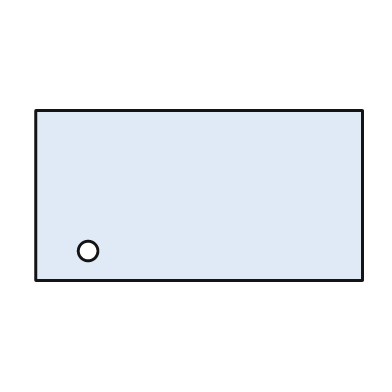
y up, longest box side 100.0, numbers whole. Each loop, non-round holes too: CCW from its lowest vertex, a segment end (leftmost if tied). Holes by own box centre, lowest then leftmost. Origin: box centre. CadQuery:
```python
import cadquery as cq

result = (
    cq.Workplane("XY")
    .moveTo(-50.0, -26.0)
    .lineTo(50.0, -26.0)
    .lineTo(50.0, 26.0)
    .lineTo(-50.0, 26.0)
    .close()
    .moveTo(-34.0, -17.0)
    .circle(3.0)
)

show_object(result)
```